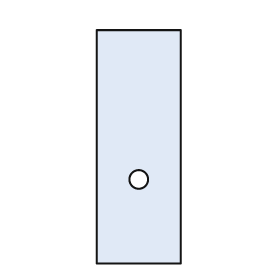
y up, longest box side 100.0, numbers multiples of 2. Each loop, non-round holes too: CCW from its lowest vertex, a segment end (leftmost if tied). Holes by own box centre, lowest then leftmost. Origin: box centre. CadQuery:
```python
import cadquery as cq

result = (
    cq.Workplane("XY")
    .moveTo(-18.0, -50.0)
    .lineTo(18.0, -50.0)
    .lineTo(18.0, 50.0)
    .lineTo(-18.0, 50.0)
    .close()
    .moveTo(0.0, -14.0)
    .circle(4.0)
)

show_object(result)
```